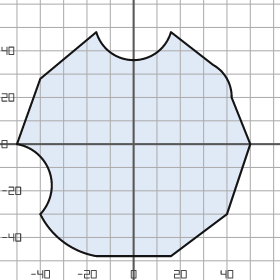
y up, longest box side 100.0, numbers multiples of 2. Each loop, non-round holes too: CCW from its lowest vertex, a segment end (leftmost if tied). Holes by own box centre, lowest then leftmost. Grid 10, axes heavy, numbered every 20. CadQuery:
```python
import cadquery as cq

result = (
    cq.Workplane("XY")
    .moveTo(-16.0, -48.0)
    .lineTo(16.0, -48.0)
    .lineTo(40.0, -30.0)
    .lineTo(50.0, 0.0)
    .lineTo(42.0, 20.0)
    .threePointArc((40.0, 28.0), (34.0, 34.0))
    .lineTo(16.0, 48.0)
    .threePointArc((0.0, 36.0), (-16.0, 48.0))
    .lineTo(-40.0, 28.0)
    .lineTo(-50.0, 0.0)
    .threePointArc((-36.0, -12.0), (-40.0, -30.0))
    .threePointArc((-30.0, -42.0), (-16.0, -48.0))
    .close()
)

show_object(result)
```